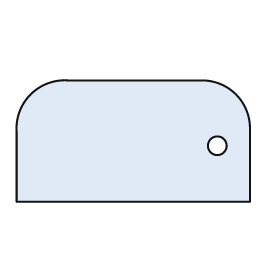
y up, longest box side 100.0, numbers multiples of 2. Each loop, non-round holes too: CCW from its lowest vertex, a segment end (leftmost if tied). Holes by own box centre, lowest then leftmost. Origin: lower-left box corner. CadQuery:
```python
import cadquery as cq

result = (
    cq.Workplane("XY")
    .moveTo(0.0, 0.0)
    .lineTo(100.0, 0.0)
    .lineTo(100.0, 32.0)
    .threePointArc((94.0, 46.0), (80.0, 52.0))
    .lineTo(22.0, 52.0)
    .threePointArc((6.0, 46.0), (0.0, 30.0))
    .close()
    .moveTo(86.0, 24.0)
    .circle(4.0)
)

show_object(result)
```